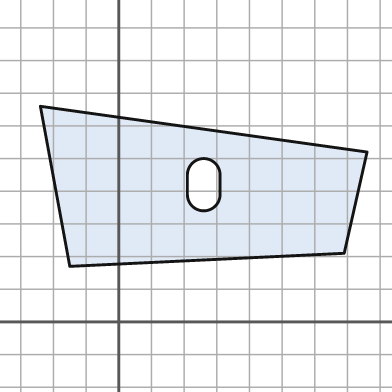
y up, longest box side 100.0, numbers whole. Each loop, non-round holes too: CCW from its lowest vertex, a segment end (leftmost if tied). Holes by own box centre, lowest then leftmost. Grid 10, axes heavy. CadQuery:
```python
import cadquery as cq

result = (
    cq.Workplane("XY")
    .moveTo(-15.0, 17.0)
    .lineTo(69.0, 21.0)
    .lineTo(76.0, 52.0)
    .lineTo(-24.0, 66.0)
    .close()
    .moveTo(21.0, 39.0)
    .threePointArc((26.0, 34.0), (31.0, 39.0))
    .lineTo(31.0, 45.0)
    .threePointArc((26.0, 50.0), (21.0, 45.0))
    .close()
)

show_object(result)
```